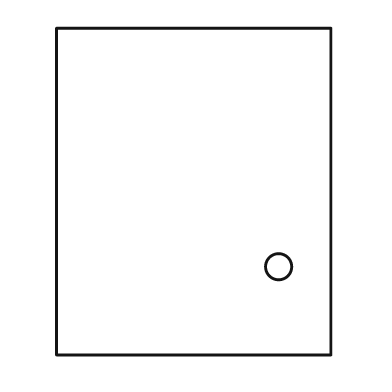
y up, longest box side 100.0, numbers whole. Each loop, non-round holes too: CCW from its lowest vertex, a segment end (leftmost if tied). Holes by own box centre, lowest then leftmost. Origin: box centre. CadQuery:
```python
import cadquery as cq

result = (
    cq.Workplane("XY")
    .moveTo(-42.0, -50.0)
    .lineTo(42.0, -50.0)
    .lineTo(42.0, 50.0)
    .lineTo(-42.0, 50.0)
    .close()
    .moveTo(26.0, -23.0)
    .circle(4.0)
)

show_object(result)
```